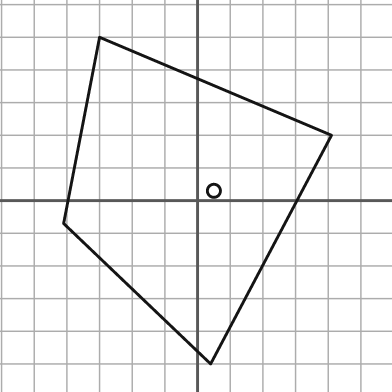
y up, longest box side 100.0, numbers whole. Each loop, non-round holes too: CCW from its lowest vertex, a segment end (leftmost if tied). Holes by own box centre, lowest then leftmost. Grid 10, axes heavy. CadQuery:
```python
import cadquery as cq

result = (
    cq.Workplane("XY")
    .moveTo(4.0, -50.0)
    .lineTo(41.0, 20.0)
    .lineTo(-30.0, 50.0)
    .lineTo(-41.0, -7.0)
    .close()
    .moveTo(5.0, 3.0)
    .circle(2.0)
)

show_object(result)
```